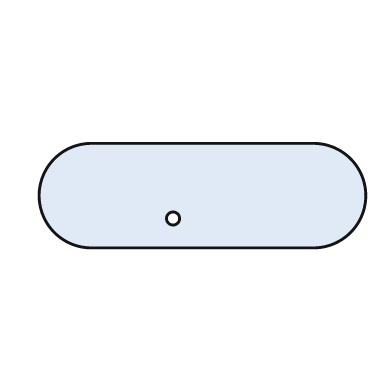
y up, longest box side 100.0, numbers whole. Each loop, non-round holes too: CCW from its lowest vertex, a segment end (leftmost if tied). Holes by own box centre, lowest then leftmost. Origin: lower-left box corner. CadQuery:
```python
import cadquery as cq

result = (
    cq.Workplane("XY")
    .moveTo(16.0, 0.0)
    .lineTo(84.0, 0.0)
    .threePointArc((100.0, 16.0), (84.0, 32.0))
    .lineTo(16.0, 32.0)
    .threePointArc((0.0, 16.0), (16.0, 0.0))
    .close()
    .moveTo(41.0, 9.0)
    .circle(2.0)
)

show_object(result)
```